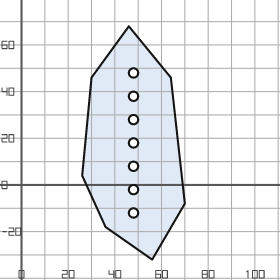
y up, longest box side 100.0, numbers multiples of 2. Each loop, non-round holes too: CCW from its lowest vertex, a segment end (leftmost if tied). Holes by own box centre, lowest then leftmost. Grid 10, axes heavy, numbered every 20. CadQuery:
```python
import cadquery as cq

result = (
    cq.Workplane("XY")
    .moveTo(56.0, -32.0)
    .lineTo(70.0, -8.0)
    .lineTo(64.0, 46.0)
    .lineTo(46.0, 68.0)
    .lineTo(30.0, 46.0)
    .lineTo(26.0, 4.0)
    .lineTo(36.0, -18.0)
    .close()
    .moveTo(48.0, -12.0)
    .circle(2.0)
    .moveTo(48.0, -2.0)
    .circle(2.0)
    .moveTo(48.0, 8.0)
    .circle(2.0)
    .moveTo(48.0, 18.0)
    .circle(2.0)
    .moveTo(48.0, 28.0)
    .circle(2.0)
    .moveTo(48.0, 38.0)
    .circle(2.0)
    .moveTo(48.0, 48.0)
    .circle(2.0)
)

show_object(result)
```